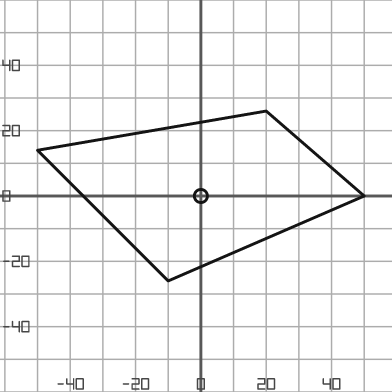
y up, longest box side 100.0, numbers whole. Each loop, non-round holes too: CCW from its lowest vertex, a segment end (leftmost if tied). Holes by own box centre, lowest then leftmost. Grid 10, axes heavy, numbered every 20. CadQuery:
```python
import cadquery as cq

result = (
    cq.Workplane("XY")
    .moveTo(-10.0, -26.0)
    .lineTo(50.0, 0.0)
    .lineTo(20.0, 26.0)
    .lineTo(-50.0, 14.0)
    .close()
    .moveTo(0.0, 0.0)
    .circle(2.0)
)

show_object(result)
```